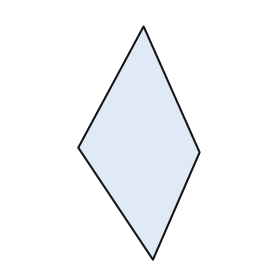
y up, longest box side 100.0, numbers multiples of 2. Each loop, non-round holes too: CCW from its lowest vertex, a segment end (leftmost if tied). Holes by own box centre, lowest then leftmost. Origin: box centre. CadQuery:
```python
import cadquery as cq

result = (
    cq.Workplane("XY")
    .moveTo(6.0, -50.0)
    .lineTo(26.0, -4.0)
    .lineTo(2.0, 50.0)
    .lineTo(-26.0, -2.0)
    .close()
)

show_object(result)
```